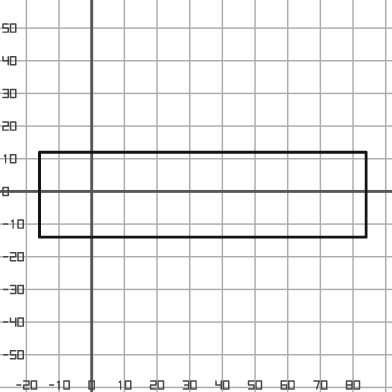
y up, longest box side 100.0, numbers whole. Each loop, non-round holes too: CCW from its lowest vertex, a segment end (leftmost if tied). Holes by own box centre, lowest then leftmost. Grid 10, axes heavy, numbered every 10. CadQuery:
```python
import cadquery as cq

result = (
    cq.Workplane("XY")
    .moveTo(-16.0, -14.0)
    .lineTo(84.0, -14.0)
    .lineTo(84.0, 12.0)
    .lineTo(-16.0, 12.0)
    .close()
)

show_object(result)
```